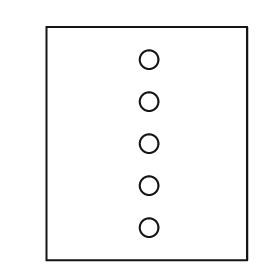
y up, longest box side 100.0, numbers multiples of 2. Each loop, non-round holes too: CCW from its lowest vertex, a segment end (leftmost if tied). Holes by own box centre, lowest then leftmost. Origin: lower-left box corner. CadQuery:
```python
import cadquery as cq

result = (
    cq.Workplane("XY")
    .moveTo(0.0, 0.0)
    .lineTo(86.0, 0.0)
    .lineTo(86.0, 100.0)
    .lineTo(0.0, 100.0)
    .close()
    .moveTo(44.0, 14.0)
    .circle(4.0)
    .moveTo(44.0, 32.0)
    .circle(4.0)
    .moveTo(44.0, 50.0)
    .circle(4.0)
    .moveTo(44.0, 68.0)
    .circle(4.0)
    .moveTo(44.0, 86.0)
    .circle(4.0)
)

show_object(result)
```